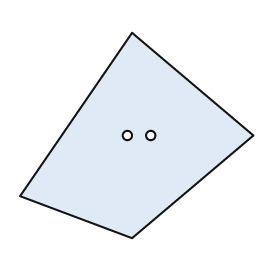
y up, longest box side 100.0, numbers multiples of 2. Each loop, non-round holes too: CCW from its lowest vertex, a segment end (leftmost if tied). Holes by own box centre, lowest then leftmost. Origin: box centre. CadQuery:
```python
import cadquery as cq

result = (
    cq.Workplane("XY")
    .moveTo(-2.0, -44.0)
    .lineTo(50.0, 0.0)
    .lineTo(-2.0, 44.0)
    .lineTo(-50.0, -26.0)
    .close()
    .moveTo(-4.0, 0.0)
    .circle(2.0)
    .moveTo(6.0, 0.0)
    .circle(2.0)
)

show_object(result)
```